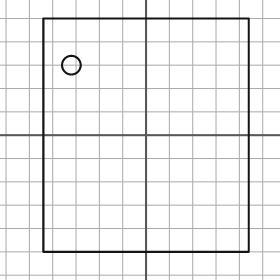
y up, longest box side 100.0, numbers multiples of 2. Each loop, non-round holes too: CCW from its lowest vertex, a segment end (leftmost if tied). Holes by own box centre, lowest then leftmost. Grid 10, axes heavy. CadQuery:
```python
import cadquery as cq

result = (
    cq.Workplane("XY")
    .moveTo(-44.0, -50.0)
    .lineTo(44.0, -50.0)
    .lineTo(44.0, 50.0)
    .lineTo(-44.0, 50.0)
    .close()
    .moveTo(-32.0, 30.0)
    .circle(4.0)
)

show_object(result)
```